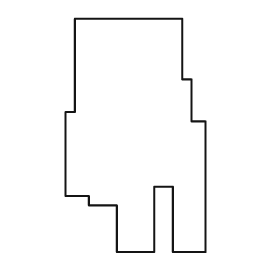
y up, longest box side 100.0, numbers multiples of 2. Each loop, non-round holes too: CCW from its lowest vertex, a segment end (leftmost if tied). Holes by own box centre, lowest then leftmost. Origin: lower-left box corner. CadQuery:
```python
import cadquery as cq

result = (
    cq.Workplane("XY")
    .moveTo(22.0, 0.0)
    .lineTo(38.0, 0.0)
    .lineTo(38.0, 28.0)
    .lineTo(46.0, 28.0)
    .lineTo(46.0, 0.0)
    .lineTo(60.0, 0.0)
    .lineTo(60.0, 56.0)
    .lineTo(54.0, 56.0)
    .lineTo(54.0, 74.0)
    .lineTo(50.0, 74.0)
    .lineTo(50.0, 100.0)
    .lineTo(4.0, 100.0)
    .lineTo(4.0, 60.0)
    .lineTo(0.0, 60.0)
    .lineTo(0.0, 24.0)
    .lineTo(10.0, 24.0)
    .lineTo(10.0, 20.0)
    .lineTo(22.0, 20.0)
    .close()
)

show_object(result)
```